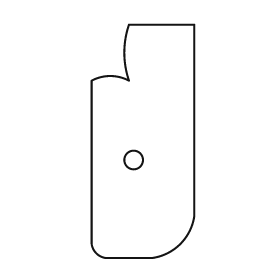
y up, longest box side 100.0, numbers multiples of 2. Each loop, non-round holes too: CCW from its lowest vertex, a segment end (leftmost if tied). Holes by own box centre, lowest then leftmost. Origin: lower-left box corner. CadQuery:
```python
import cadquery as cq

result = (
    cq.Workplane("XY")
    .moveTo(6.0, 0.0)
    .lineTo(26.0, 0.0)
    .threePointArc((38.0, 6.0), (44.0, 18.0))
    .lineTo(44.0, 100.0)
    .lineTo(16.0, 100.0)
    .threePointArc((14.0, 88.0), (16.0, 76.0))
    .threePointArc((8.0, 78.0), (0.0, 76.0))
    .lineTo(0.0, 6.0)
    .threePointArc((2.0, 2.0), (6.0, 0.0))
    .close()
    .moveTo(18.0, 42.0)
    .circle(4.0)
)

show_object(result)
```